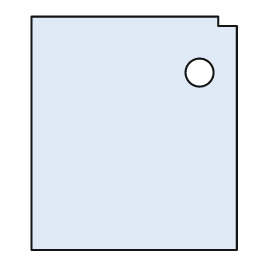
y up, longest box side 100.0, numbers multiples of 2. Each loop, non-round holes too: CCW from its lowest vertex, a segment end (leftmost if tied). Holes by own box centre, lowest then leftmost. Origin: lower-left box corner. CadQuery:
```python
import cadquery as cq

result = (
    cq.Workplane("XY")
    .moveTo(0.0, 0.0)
    .lineTo(88.0, 0.0)
    .lineTo(88.0, 96.0)
    .lineTo(80.0, 96.0)
    .lineTo(80.0, 100.0)
    .lineTo(0.0, 100.0)
    .close()
    .moveTo(72.0, 76.0)
    .circle(6.0)
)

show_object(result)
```